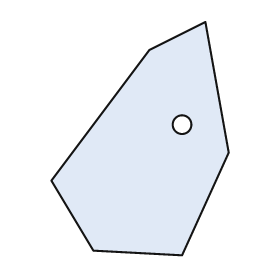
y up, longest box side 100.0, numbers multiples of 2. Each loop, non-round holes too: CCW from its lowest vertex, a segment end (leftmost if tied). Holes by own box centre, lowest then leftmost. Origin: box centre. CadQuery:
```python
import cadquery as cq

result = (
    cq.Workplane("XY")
    .moveTo(18.0, -50.0)
    .lineTo(38.0, -6.0)
    .lineTo(28.0, 50.0)
    .lineTo(4.0, 38.0)
    .lineTo(-38.0, -18.0)
    .lineTo(-20.0, -48.0)
    .close()
    .moveTo(18.0, 6.0)
    .circle(4.0)
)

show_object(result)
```